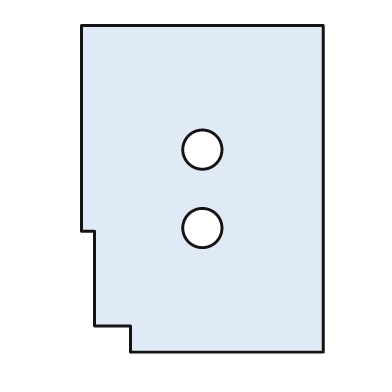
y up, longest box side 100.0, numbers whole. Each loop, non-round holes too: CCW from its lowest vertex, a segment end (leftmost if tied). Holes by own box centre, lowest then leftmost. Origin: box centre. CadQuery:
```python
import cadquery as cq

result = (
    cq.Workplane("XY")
    .moveTo(-22.0, -50.0)
    .lineTo(37.0, -50.0)
    .lineTo(37.0, 50.0)
    .lineTo(-37.0, 50.0)
    .lineTo(-37.0, -13.0)
    .lineTo(-33.0, -13.0)
    .lineTo(-33.0, -42.0)
    .lineTo(-22.0, -42.0)
    .close()
    .moveTo(0.0, -12.0)
    .circle(6.0)
    .moveTo(0.0, 12.0)
    .circle(6.0)
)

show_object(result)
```